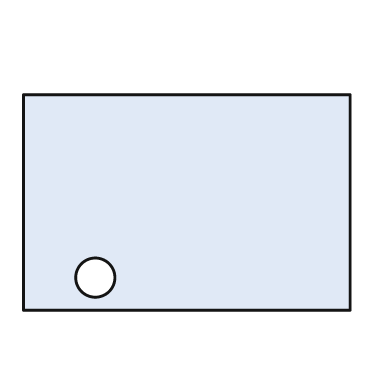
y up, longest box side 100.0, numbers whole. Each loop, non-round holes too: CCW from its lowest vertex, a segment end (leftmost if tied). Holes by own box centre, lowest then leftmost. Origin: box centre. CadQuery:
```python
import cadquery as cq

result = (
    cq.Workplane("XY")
    .moveTo(-50.0, -33.0)
    .lineTo(50.0, -33.0)
    .lineTo(50.0, 33.0)
    .lineTo(-50.0, 33.0)
    .close()
    .moveTo(-28.0, -23.0)
    .circle(6.0)
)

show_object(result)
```